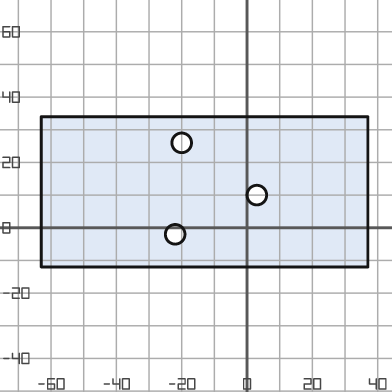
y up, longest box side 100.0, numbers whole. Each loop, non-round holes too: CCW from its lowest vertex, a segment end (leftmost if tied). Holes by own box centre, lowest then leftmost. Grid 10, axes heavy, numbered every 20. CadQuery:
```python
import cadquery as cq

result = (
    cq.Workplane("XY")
    .moveTo(-63.0, -12.0)
    .lineTo(37.0, -12.0)
    .lineTo(37.0, 34.0)
    .lineTo(-63.0, 34.0)
    .close()
    .moveTo(-22.0, -2.0)
    .circle(3.0)
    .moveTo(3.0, 10.0)
    .circle(3.0)
    .moveTo(-20.0, 26.0)
    .circle(3.0)
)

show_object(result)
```